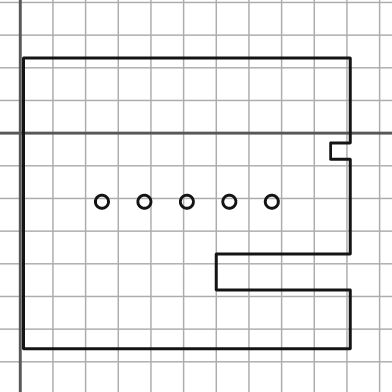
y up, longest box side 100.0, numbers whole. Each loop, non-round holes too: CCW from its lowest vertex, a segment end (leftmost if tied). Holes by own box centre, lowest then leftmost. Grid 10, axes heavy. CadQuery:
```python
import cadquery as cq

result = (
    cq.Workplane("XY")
    .moveTo(1.0, -66.0)
    .lineTo(101.0, -66.0)
    .lineTo(101.0, -48.0)
    .lineTo(60.0, -48.0)
    .lineTo(60.0, -37.0)
    .lineTo(101.0, -37.0)
    .lineTo(101.0, -8.0)
    .lineTo(95.0, -8.0)
    .lineTo(95.0, -3.0)
    .lineTo(101.0, -3.0)
    .lineTo(101.0, 23.0)
    .lineTo(1.0, 23.0)
    .close()
    .moveTo(25.0, -21.0)
    .circle(2.0)
    .moveTo(38.0, -21.0)
    .circle(2.0)
    .moveTo(51.0, -21.0)
    .circle(2.0)
    .moveTo(64.0, -21.0)
    .circle(2.0)
    .moveTo(77.0, -21.0)
    .circle(2.0)
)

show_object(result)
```